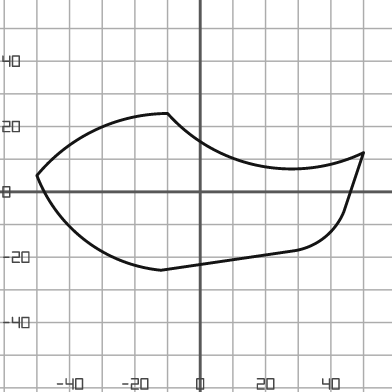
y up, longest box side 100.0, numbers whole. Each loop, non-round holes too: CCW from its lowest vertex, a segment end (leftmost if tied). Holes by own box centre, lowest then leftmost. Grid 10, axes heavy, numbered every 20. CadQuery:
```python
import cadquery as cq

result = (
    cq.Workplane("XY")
    .moveTo(-12.0, -24.0)
    .lineTo(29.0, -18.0)
    .threePointArc((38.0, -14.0), (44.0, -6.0))
    .lineTo(50.0, 12.0)
    .threePointArc((18.0, 8.0), (-10.0, 24.0))
    .threePointArc((-32.0, 19.0), (-50.0, 5.0))
    .threePointArc((-35.0, -15.0), (-12.0, -24.0))
    .close()
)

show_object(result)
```